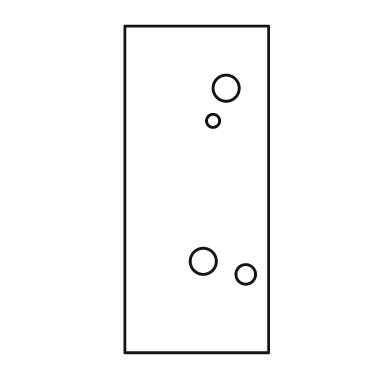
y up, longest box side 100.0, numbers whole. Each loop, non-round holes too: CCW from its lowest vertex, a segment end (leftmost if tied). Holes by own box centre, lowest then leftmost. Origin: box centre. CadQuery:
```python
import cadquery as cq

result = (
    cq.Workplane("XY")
    .moveTo(-22.0, -50.0)
    .lineTo(22.0, -50.0)
    .lineTo(22.0, 50.0)
    .lineTo(-22.0, 50.0)
    .close()
    .moveTo(15.0, -26.0)
    .circle(3.0)
    .moveTo(2.0, -22.0)
    .circle(4.0)
    .moveTo(5.0, 21.0)
    .circle(2.0)
    .moveTo(9.0, 31.0)
    .circle(4.0)
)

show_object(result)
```